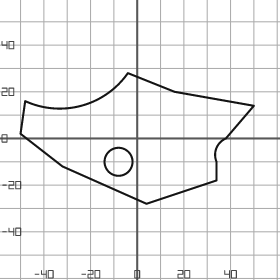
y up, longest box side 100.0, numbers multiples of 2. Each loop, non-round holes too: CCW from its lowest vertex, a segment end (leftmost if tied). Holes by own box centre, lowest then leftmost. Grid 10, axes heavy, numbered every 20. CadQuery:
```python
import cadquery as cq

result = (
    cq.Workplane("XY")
    .moveTo(4.0, -28.0)
    .lineTo(34.0, -18.0)
    .lineTo(34.0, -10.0)
    .threePointArc((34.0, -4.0), (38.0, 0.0))
    .lineTo(50.0, 14.0)
    .lineTo(16.0, 20.0)
    .lineTo(-4.0, 28.0)
    .threePointArc((-24.0, 14.0), (-48.0, 16.0))
    .lineTo(-50.0, 2.0)
    .lineTo(-32.0, -12.0)
    .close()
    .moveTo(-8.0, -10.0)
    .circle(6.0)
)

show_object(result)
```